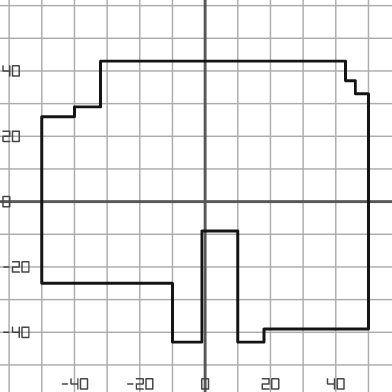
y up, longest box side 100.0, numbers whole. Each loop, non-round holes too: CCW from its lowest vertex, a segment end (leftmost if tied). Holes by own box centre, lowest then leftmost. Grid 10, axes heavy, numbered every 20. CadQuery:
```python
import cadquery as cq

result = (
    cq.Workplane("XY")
    .moveTo(-10.0, -43.0)
    .lineTo(-1.0, -43.0)
    .lineTo(-1.0, -9.0)
    .lineTo(10.0, -9.0)
    .lineTo(10.0, -43.0)
    .lineTo(18.0, -43.0)
    .lineTo(18.0, -39.0)
    .lineTo(50.0, -39.0)
    .lineTo(50.0, 33.0)
    .lineTo(46.0, 33.0)
    .lineTo(46.0, 37.0)
    .lineTo(43.0, 37.0)
    .lineTo(43.0, 43.0)
    .lineTo(-32.0, 43.0)
    .lineTo(-32.0, 29.0)
    .lineTo(-40.0, 29.0)
    .lineTo(-40.0, 26.0)
    .lineTo(-50.0, 26.0)
    .lineTo(-50.0, -25.0)
    .lineTo(-10.0, -25.0)
    .close()
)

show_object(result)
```